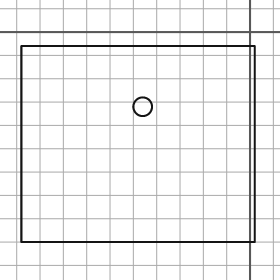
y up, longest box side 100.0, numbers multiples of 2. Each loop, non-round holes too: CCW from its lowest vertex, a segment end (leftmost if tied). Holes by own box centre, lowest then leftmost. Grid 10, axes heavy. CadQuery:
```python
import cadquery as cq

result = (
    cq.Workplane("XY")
    .moveTo(-98.0, -90.0)
    .lineTo(2.0, -90.0)
    .lineTo(2.0, -6.0)
    .lineTo(-98.0, -6.0)
    .close()
    .moveTo(-46.0, -32.0)
    .circle(4.0)
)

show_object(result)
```